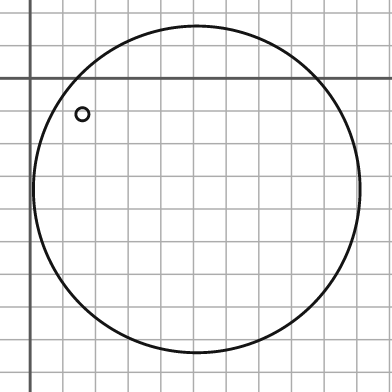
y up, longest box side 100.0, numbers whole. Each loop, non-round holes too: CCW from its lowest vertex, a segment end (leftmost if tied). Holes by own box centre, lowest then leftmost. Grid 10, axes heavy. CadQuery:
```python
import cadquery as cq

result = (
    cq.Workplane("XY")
    .moveTo(51.0, -34.0)
    .circle(50.0)
    .moveTo(16.0, -11.0)
    .circle(2.0)
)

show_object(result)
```